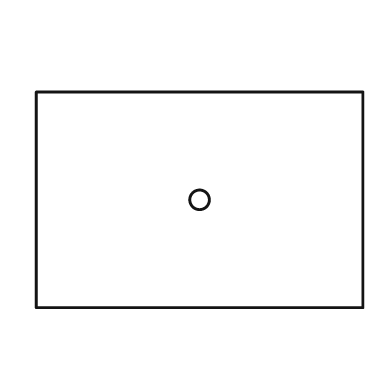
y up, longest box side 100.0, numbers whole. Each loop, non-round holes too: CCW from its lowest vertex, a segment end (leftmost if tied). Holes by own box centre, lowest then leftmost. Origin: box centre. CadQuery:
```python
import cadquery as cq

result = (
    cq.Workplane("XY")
    .moveTo(-50.0, -33.0)
    .lineTo(50.0, -33.0)
    .lineTo(50.0, 33.0)
    .lineTo(-50.0, 33.0)
    .close()
    .moveTo(0.0, 0.0)
    .circle(3.0)
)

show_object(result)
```